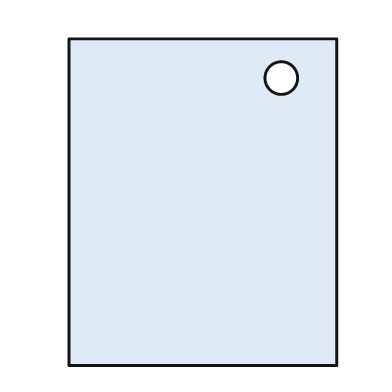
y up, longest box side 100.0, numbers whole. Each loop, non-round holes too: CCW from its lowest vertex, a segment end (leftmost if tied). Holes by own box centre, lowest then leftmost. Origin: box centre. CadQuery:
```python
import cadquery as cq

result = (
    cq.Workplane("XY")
    .moveTo(-41.0, -50.0)
    .lineTo(41.0, -50.0)
    .lineTo(41.0, 50.0)
    .lineTo(-41.0, 50.0)
    .close()
    .moveTo(24.0, 38.0)
    .circle(5.0)
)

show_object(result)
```